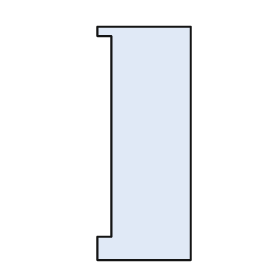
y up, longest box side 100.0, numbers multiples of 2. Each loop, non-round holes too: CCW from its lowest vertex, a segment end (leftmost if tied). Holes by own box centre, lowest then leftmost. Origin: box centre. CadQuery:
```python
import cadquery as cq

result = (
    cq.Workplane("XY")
    .moveTo(-20.0, -50.0)
    .lineTo(20.0, -50.0)
    .lineTo(20.0, 50.0)
    .lineTo(-20.0, 50.0)
    .lineTo(-20.0, 46.0)
    .lineTo(-14.0, 46.0)
    .lineTo(-14.0, -40.0)
    .lineTo(-20.0, -40.0)
    .close()
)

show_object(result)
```